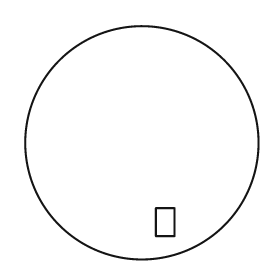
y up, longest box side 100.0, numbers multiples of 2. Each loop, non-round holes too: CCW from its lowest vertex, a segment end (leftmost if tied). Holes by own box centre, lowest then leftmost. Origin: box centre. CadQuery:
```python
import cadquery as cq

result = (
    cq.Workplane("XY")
    .moveTo(0.0, 0.0)
    .circle(50.0)
    .moveTo(6.0, -40.0)
    .lineTo(14.0, -40.0)
    .lineTo(14.0, -28.0)
    .lineTo(6.0, -28.0)
    .close()
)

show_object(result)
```